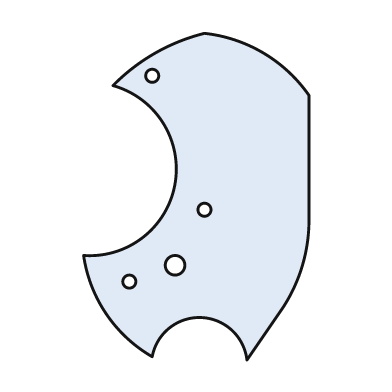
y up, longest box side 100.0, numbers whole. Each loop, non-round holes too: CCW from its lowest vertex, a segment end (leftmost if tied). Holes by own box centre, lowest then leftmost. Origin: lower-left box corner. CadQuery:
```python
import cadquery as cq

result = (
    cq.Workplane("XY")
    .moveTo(50.0, 0.0)
    .lineTo(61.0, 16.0)
    .threePointArc((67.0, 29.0), (69.0, 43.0))
    .lineTo(69.0, 81.0)
    .threePointArc((55.0, 94.0), (37.0, 100.0))
    .threePointArc((22.0, 94.0), (9.0, 84.0))
    .threePointArc((28.0, 54.0), (0.0, 32.0))
    .threePointArc((7.0, 14.0), (21.0, 1.0))
    .threePointArc((36.0, 13.0), (50.0, 0.0))
    .close()
    .moveTo(14.0, 24.0)
    .circle(2.0)
    .moveTo(28.0, 29.0)
    .circle(3.0)
    .moveTo(37.0, 46.0)
    .circle(2.0)
    .moveTo(21.0, 87.0)
    .circle(2.0)
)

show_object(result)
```